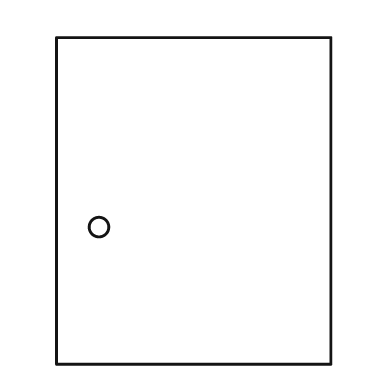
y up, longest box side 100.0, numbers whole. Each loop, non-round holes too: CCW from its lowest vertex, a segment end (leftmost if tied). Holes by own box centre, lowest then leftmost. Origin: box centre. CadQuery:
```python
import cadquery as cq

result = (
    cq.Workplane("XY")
    .moveTo(-42.0, -50.0)
    .lineTo(42.0, -50.0)
    .lineTo(42.0, 50.0)
    .lineTo(-42.0, 50.0)
    .close()
    .moveTo(-29.0, -8.0)
    .circle(3.0)
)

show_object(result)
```